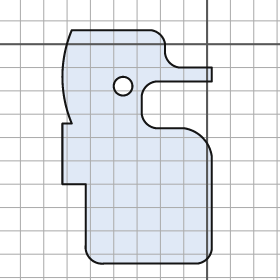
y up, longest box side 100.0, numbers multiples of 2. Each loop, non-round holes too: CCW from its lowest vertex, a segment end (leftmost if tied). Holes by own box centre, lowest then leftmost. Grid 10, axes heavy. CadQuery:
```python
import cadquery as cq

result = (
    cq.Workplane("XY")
    .moveTo(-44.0, -94.0)
    .lineTo(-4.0, -94.0)
    .threePointArc((0.0, -92.0), (2.0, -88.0))
    .lineTo(2.0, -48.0)
    .threePointArc((-2.0, -40.0), (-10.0, -36.0))
    .lineTo(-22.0, -36.0)
    .threePointArc((-26.0, -34.0), (-28.0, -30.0))
    .lineTo(-28.0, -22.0)
    .threePointArc((-26.0, -18.0), (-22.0, -16.0))
    .lineTo(2.0, -16.0)
    .lineTo(2.0, -10.0)
    .lineTo(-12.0, -10.0)
    .threePointArc((-16.0, -8.0), (-18.0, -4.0))
    .lineTo(-18.0, 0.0)
    .threePointArc((-20.0, 4.0), (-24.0, 6.0))
    .lineTo(-58.0, 6.0)
    .threePointArc((-62.0, -14.0), (-58.0, -34.0))
    .lineTo(-62.0, -34.0)
    .lineTo(-62.0, -60.0)
    .lineTo(-52.0, -60.0)
    .lineTo(-52.0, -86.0)
    .threePointArc((-50.0, -92.0), (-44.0, -94.0))
    .close()
    .moveTo(-36.0, -18.0)
    .circle(4.0)
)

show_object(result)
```